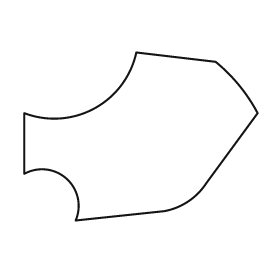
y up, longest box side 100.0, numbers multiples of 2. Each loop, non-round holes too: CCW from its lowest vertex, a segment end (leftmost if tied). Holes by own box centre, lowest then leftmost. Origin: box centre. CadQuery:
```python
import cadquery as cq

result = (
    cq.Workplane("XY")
    .moveTo(-28.0, -36.0)
    .lineTo(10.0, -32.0)
    .threePointArc((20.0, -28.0), (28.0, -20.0))
    .lineTo(50.0, 10.0)
    .threePointArc((42.0, 22.0), (32.0, 32.0))
    .lineTo(-2.0, 36.0)
    .threePointArc((-20.0, 12.0), (-50.0, 10.0))
    .lineTo(-50.0, -16.0)
    .threePointArc((-32.0, -18.0), (-28.0, -36.0))
    .close()
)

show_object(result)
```